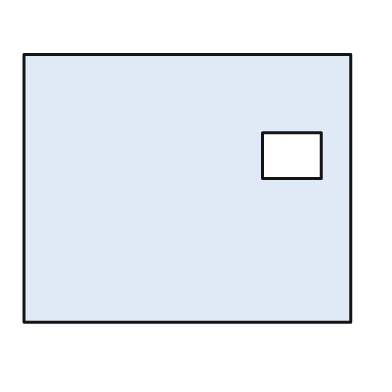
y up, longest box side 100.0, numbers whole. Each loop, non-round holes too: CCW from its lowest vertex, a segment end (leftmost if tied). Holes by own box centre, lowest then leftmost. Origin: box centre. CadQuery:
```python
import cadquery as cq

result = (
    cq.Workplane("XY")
    .moveTo(-50.0, -41.0)
    .lineTo(50.0, -41.0)
    .lineTo(50.0, 41.0)
    .lineTo(-50.0, 41.0)
    .close()
    .moveTo(23.0, 3.0)
    .lineTo(41.0, 3.0)
    .lineTo(41.0, 17.0)
    .lineTo(23.0, 17.0)
    .close()
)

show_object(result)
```